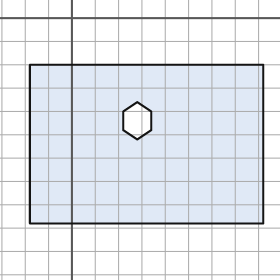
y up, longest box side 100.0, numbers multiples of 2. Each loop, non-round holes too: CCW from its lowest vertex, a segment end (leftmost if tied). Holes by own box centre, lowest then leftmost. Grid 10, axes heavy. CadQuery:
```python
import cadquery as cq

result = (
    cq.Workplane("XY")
    .moveTo(-18.0, -88.0)
    .lineTo(82.0, -88.0)
    .lineTo(82.0, -20.0)
    .lineTo(-18.0, -20.0)
    .close()
    .moveTo(28.0, -52.0)
    .lineTo(34.0, -48.0)
    .lineTo(34.0, -40.0)
    .lineTo(28.0, -36.0)
    .lineTo(22.0, -40.0)
    .lineTo(22.0, -48.0)
    .close()
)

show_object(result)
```